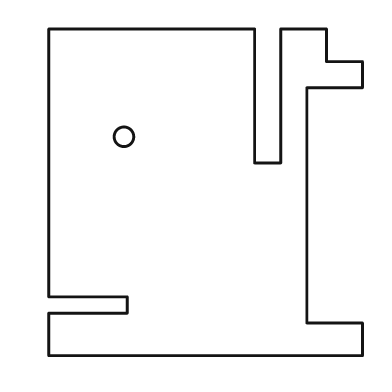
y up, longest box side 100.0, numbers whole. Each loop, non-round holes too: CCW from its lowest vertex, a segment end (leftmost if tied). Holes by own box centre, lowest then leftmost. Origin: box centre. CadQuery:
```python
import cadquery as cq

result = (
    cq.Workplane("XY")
    .moveTo(-48.0, -50.0)
    .lineTo(48.0, -50.0)
    .lineTo(48.0, -40.0)
    .lineTo(31.0, -40.0)
    .lineTo(31.0, 32.0)
    .lineTo(48.0, 32.0)
    .lineTo(48.0, 40.0)
    .lineTo(37.0, 40.0)
    .lineTo(37.0, 50.0)
    .lineTo(23.0, 50.0)
    .lineTo(23.0, 9.0)
    .lineTo(15.0, 9.0)
    .lineTo(15.0, 50.0)
    .lineTo(-48.0, 50.0)
    .lineTo(-48.0, -32.0)
    .lineTo(-24.0, -32.0)
    .lineTo(-24.0, -37.0)
    .lineTo(-48.0, -37.0)
    .close()
    .moveTo(-25.0, 17.0)
    .circle(3.0)
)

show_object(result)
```